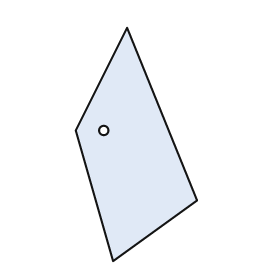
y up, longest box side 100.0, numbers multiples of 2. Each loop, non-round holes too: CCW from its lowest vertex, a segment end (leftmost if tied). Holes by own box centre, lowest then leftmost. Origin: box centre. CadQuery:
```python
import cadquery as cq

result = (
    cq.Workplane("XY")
    .moveTo(-10.0, -50.0)
    .lineTo(26.0, -24.0)
    .lineTo(-4.0, 50.0)
    .lineTo(-26.0, 6.0)
    .close()
    .moveTo(-14.0, 6.0)
    .circle(2.0)
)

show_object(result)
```